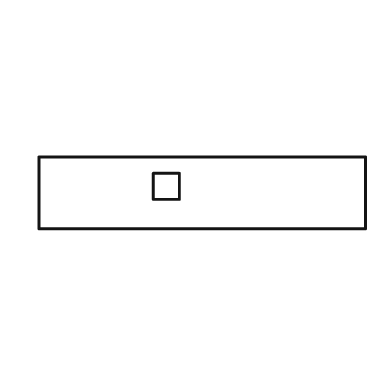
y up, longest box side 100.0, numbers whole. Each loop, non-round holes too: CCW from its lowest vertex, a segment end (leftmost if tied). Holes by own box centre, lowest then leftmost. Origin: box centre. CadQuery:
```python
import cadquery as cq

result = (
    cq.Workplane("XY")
    .moveTo(-50.0, -11.0)
    .lineTo(50.0, -11.0)
    .lineTo(50.0, 11.0)
    .lineTo(-50.0, 11.0)
    .close()
    .moveTo(-15.0, -2.0)
    .lineTo(-7.0, -2.0)
    .lineTo(-7.0, 6.0)
    .lineTo(-15.0, 6.0)
    .close()
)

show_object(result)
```